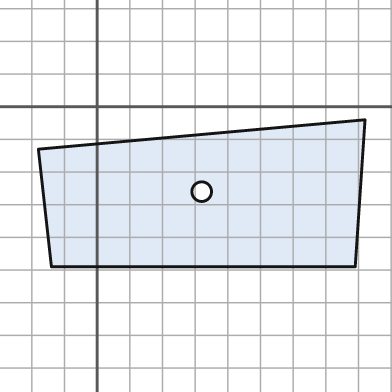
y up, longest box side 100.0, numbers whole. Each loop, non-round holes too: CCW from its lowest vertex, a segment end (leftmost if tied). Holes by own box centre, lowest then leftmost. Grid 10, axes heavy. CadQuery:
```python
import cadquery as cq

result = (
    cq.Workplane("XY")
    .moveTo(-14.0, -49.0)
    .lineTo(79.0, -49.0)
    .lineTo(82.0, -4.0)
    .lineTo(-18.0, -13.0)
    .close()
    .moveTo(32.0, -26.0)
    .circle(3.0)
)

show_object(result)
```